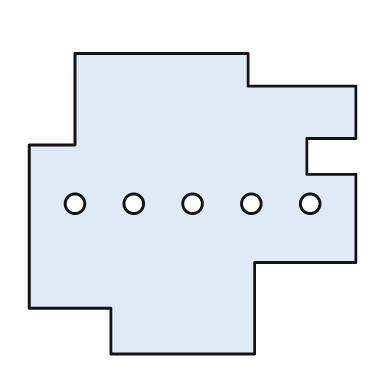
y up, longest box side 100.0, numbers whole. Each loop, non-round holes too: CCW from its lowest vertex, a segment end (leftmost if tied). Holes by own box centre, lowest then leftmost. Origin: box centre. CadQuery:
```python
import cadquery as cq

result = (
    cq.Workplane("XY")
    .moveTo(-25.0, -46.0)
    .lineTo(19.0, -46.0)
    .lineTo(19.0, -18.0)
    .lineTo(50.0, -18.0)
    .lineTo(50.0, 9.0)
    .lineTo(35.0, 9.0)
    .lineTo(35.0, 20.0)
    .lineTo(50.0, 20.0)
    .lineTo(50.0, 36.0)
    .lineTo(17.0, 36.0)
    .lineTo(17.0, 46.0)
    .lineTo(-36.0, 46.0)
    .lineTo(-36.0, 18.0)
    .lineTo(-50.0, 18.0)
    .lineTo(-50.0, -32.0)
    .lineTo(-25.0, -32.0)
    .close()
    .moveTo(-36.0, 0.0)
    .circle(3.0)
    .moveTo(-18.0, 0.0)
    .circle(3.0)
    .moveTo(0.0, 0.0)
    .circle(3.0)
    .moveTo(18.0, 0.0)
    .circle(3.0)
    .moveTo(36.0, 0.0)
    .circle(3.0)
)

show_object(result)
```